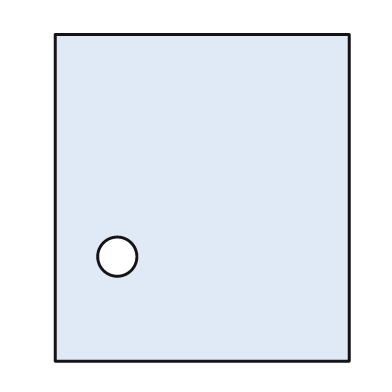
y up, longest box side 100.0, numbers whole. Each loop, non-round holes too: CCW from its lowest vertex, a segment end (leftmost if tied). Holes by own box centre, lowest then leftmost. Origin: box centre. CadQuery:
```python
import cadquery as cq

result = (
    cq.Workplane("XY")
    .moveTo(-45.0, -50.0)
    .lineTo(45.0, -50.0)
    .lineTo(45.0, 50.0)
    .lineTo(-45.0, 50.0)
    .close()
    .moveTo(-26.0, -18.0)
    .circle(6.0)
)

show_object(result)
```